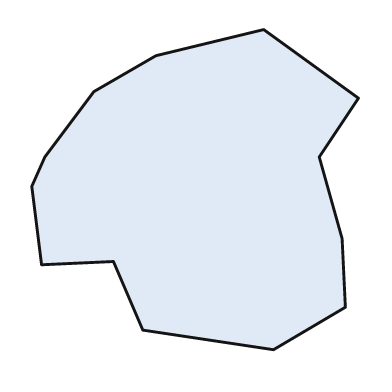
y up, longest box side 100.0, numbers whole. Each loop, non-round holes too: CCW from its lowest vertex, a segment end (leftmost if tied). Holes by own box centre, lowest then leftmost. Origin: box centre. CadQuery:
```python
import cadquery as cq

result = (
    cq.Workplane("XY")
    .moveTo(24.0, -49.0)
    .lineTo(46.0, -36.0)
    .lineTo(45.0, -15.0)
    .lineTo(38.0, 10.0)
    .lineTo(50.0, 28.0)
    .lineTo(21.0, 49.0)
    .lineTo(-12.0, 41.0)
    .lineTo(-31.0, 30.0)
    .lineTo(-46.0, 10.0)
    .lineTo(-50.0, 1.0)
    .lineTo(-47.0, -23.0)
    .lineTo(-25.0, -22.0)
    .lineTo(-16.0, -43.0)
    .close()
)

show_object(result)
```